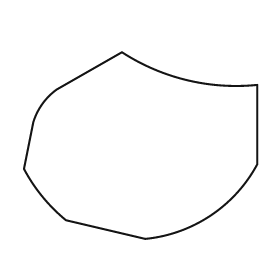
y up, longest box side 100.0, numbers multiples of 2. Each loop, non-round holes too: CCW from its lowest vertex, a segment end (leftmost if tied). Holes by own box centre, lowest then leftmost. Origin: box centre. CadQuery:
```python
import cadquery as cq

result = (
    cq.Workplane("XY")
    .moveTo(2.0, -40.0)
    .threePointArc((30.0, -30.0), (50.0, -8.0))
    .lineTo(50.0, 26.0)
    .threePointArc((20.0, 28.0), (-8.0, 40.0))
    .lineTo(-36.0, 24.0)
    .threePointArc((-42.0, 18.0), (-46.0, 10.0))
    .lineTo(-50.0, -10.0)
    .threePointArc((-42.0, -22.0), (-32.0, -32.0))
    .close()
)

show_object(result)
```